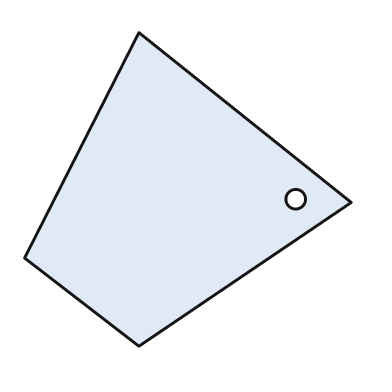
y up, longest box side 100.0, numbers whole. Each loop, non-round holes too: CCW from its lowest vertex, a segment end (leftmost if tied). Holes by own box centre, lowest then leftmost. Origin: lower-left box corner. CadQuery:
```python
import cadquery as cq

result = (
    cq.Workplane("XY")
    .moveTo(35.0, 0.0)
    .lineTo(100.0, 44.0)
    .lineTo(35.0, 96.0)
    .lineTo(0.0, 27.0)
    .close()
    .moveTo(83.0, 45.0)
    .circle(3.0)
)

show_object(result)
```